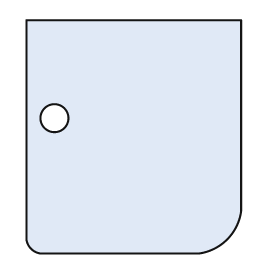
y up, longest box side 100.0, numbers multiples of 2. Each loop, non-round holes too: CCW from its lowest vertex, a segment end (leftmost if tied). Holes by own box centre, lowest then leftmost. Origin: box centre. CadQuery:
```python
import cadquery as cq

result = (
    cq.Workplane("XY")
    .moveTo(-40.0, -50.0)
    .lineTo(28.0, -50.0)
    .threePointArc((40.0, -44.0), (46.0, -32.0))
    .lineTo(46.0, 50.0)
    .lineTo(-46.0, 50.0)
    .lineTo(-46.0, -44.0)
    .threePointArc((-44.0, -48.0), (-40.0, -50.0))
    .close()
    .moveTo(-34.0, 8.0)
    .circle(6.0)
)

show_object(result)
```